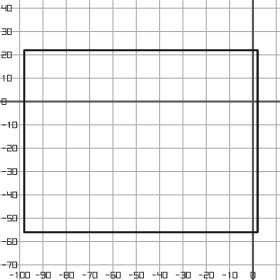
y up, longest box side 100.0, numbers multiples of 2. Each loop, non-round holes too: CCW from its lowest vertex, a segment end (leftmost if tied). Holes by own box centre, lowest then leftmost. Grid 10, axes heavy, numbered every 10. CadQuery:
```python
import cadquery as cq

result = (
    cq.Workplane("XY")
    .moveTo(-98.0, -56.0)
    .lineTo(2.0, -56.0)
    .lineTo(2.0, 22.0)
    .lineTo(-98.0, 22.0)
    .close()
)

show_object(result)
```